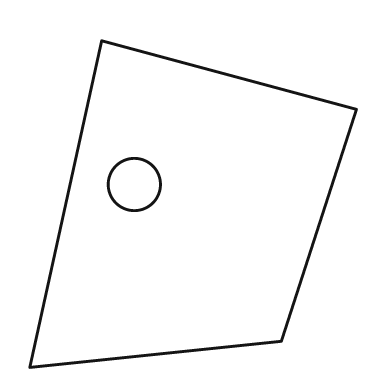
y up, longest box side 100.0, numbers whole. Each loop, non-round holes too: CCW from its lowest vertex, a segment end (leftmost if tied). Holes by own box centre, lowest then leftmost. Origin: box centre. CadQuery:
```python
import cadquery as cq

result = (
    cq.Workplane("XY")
    .moveTo(-50.0, -50.0)
    .lineTo(27.0, -42.0)
    .lineTo(50.0, 29.0)
    .lineTo(-28.0, 50.0)
    .close()
    .moveTo(-18.0, 6.0)
    .circle(8.0)
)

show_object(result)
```